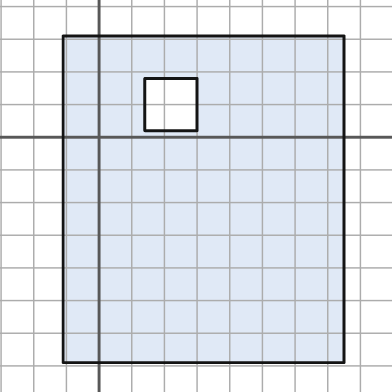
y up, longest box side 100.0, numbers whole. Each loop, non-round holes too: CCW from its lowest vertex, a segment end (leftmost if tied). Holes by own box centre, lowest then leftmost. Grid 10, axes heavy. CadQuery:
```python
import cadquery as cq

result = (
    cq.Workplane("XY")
    .moveTo(-11.0, -69.0)
    .lineTo(75.0, -69.0)
    .lineTo(75.0, 31.0)
    .lineTo(-11.0, 31.0)
    .close()
    .moveTo(14.0, 2.0)
    .lineTo(30.0, 2.0)
    .lineTo(30.0, 18.0)
    .lineTo(14.0, 18.0)
    .close()
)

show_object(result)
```